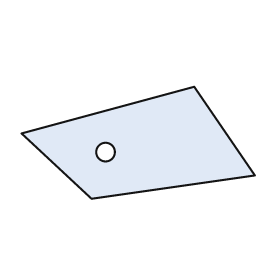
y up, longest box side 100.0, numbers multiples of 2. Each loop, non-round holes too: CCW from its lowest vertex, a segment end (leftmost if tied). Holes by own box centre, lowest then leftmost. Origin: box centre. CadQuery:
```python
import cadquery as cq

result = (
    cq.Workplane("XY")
    .moveTo(-20.0, -24.0)
    .lineTo(50.0, -14.0)
    .lineTo(24.0, 24.0)
    .lineTo(-50.0, 4.0)
    .close()
    .moveTo(-14.0, -4.0)
    .circle(4.0)
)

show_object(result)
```